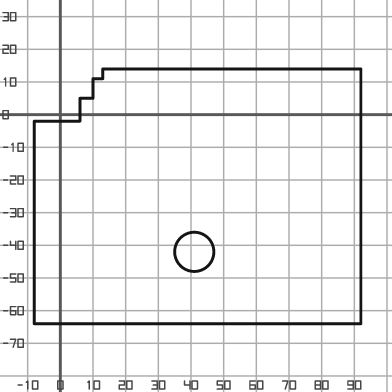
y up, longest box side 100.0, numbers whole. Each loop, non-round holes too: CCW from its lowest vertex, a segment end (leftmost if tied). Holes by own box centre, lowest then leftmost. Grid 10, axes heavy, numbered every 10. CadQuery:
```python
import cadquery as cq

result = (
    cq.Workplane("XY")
    .moveTo(-8.0, -64.0)
    .lineTo(92.0, -64.0)
    .lineTo(92.0, 14.0)
    .lineTo(13.0, 14.0)
    .lineTo(13.0, 11.0)
    .lineTo(10.0, 11.0)
    .lineTo(10.0, 5.0)
    .lineTo(6.0, 5.0)
    .lineTo(6.0, -2.0)
    .lineTo(-8.0, -2.0)
    .close()
    .moveTo(41.0, -42.0)
    .circle(6.0)
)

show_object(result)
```